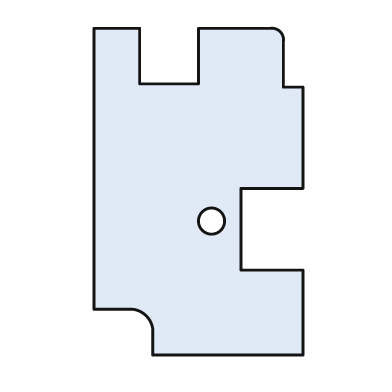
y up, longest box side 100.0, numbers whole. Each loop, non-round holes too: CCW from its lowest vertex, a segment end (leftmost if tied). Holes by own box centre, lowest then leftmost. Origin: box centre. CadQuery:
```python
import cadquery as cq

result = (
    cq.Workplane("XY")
    .moveTo(-14.0, -50.0)
    .lineTo(32.0, -50.0)
    .lineTo(32.0, -24.0)
    .lineTo(13.0, -24.0)
    .lineTo(13.0, 1.0)
    .lineTo(32.0, 1.0)
    .lineTo(32.0, 32.0)
    .lineTo(26.0, 32.0)
    .lineTo(26.0, 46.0)
    .threePointArc((25.0, 49.0), (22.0, 50.0))
    .lineTo(0.0, 50.0)
    .lineTo(0.0, 33.0)
    .lineTo(-18.0, 33.0)
    .lineTo(-18.0, 50.0)
    .lineTo(-32.0, 50.0)
    .lineTo(-32.0, -36.0)
    .lineTo(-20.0, -36.0)
    .threePointArc((-16.0, -38.0), (-14.0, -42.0))
    .close()
    .moveTo(4.0, -9.0)
    .circle(4.0)
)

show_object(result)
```